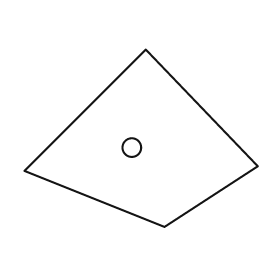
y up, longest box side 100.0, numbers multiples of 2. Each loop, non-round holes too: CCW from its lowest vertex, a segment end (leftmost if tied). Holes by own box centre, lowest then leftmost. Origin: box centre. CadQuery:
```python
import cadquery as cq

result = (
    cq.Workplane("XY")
    .moveTo(10.0, -38.0)
    .lineTo(50.0, -12.0)
    .lineTo(2.0, 38.0)
    .lineTo(-50.0, -14.0)
    .close()
    .moveTo(-4.0, -4.0)
    .circle(4.0)
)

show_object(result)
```